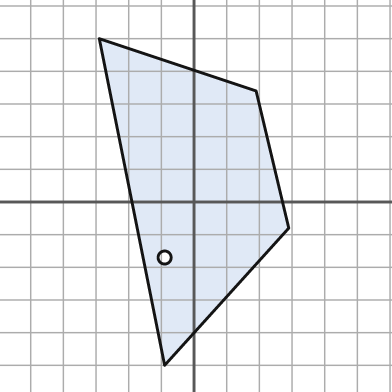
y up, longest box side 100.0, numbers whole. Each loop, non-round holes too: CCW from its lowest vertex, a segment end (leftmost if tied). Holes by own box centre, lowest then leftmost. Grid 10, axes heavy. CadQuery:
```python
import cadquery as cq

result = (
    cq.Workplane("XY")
    .moveTo(-9.0, -50.0)
    .lineTo(29.0, -8.0)
    .lineTo(19.0, 34.0)
    .lineTo(-29.0, 50.0)
    .close()
    .moveTo(-9.0, -17.0)
    .circle(2.0)
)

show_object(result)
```